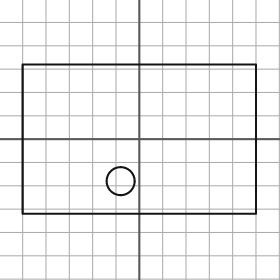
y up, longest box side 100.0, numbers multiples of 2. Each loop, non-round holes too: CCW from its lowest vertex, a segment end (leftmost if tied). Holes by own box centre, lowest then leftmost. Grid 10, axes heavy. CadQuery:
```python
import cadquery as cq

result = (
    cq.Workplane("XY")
    .moveTo(-50.0, -32.0)
    .lineTo(50.0, -32.0)
    .lineTo(50.0, 32.0)
    .lineTo(-50.0, 32.0)
    .close()
    .moveTo(-8.0, -18.0)
    .circle(6.0)
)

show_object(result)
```